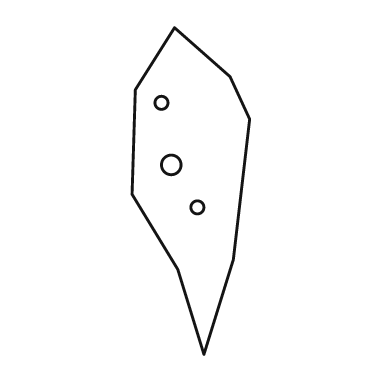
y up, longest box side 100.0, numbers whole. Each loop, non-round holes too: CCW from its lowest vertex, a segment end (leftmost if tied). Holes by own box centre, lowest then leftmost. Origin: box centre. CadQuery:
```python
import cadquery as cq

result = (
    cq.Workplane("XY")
    .moveTo(4.0, -50.0)
    .lineTo(13.0, -21.0)
    .lineTo(18.0, 22.0)
    .lineTo(12.0, 35.0)
    .lineTo(-5.0, 50.0)
    .lineTo(-17.0, 31.0)
    .lineTo(-18.0, -1.0)
    .lineTo(-4.0, -24.0)
    .close()
    .moveTo(2.0, -5.0)
    .circle(2.0)
    .moveTo(-6.0, 8.0)
    .circle(3.0)
    .moveTo(-9.0, 27.0)
    .circle(2.0)
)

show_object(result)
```